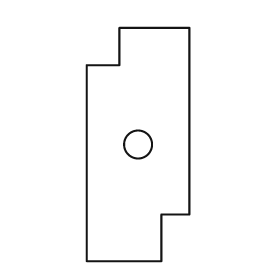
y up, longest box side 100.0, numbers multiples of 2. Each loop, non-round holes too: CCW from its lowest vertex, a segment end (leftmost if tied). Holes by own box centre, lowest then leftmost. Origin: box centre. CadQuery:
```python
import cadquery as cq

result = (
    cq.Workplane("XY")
    .moveTo(-22.0, -50.0)
    .lineTo(10.0, -50.0)
    .lineTo(10.0, -30.0)
    .lineTo(22.0, -30.0)
    .lineTo(22.0, 50.0)
    .lineTo(-8.0, 50.0)
    .lineTo(-8.0, 34.0)
    .lineTo(-22.0, 34.0)
    .close()
    .moveTo(0.0, 0.0)
    .circle(6.0)
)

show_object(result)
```